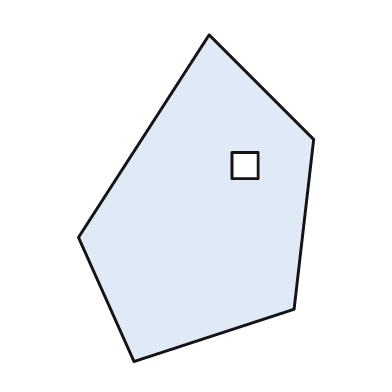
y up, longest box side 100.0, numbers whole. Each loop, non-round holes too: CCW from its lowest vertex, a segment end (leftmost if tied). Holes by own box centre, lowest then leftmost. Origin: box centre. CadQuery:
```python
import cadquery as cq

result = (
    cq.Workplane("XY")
    .moveTo(-19.0, -50.0)
    .lineTo(30.0, -34.0)
    .lineTo(36.0, 18.0)
    .lineTo(4.0, 50.0)
    .lineTo(-36.0, -12.0)
    .close()
    .moveTo(11.0, 6.0)
    .lineTo(19.0, 6.0)
    .lineTo(19.0, 14.0)
    .lineTo(11.0, 14.0)
    .close()
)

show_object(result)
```